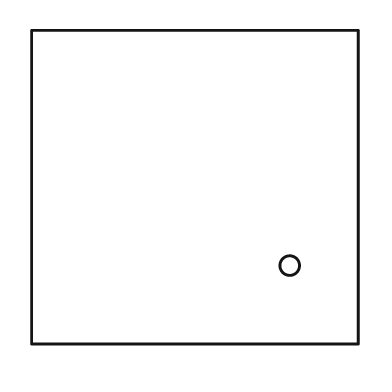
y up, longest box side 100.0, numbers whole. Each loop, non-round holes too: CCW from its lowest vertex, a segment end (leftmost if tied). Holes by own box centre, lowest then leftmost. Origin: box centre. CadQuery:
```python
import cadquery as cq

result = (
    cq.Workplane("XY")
    .moveTo(-50.0, -48.0)
    .lineTo(50.0, -48.0)
    .lineTo(50.0, 48.0)
    .lineTo(-50.0, 48.0)
    .close()
    .moveTo(29.0, -24.0)
    .circle(3.0)
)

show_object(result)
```